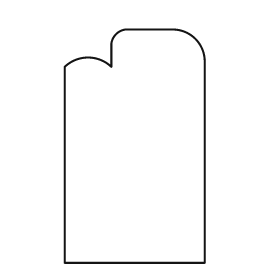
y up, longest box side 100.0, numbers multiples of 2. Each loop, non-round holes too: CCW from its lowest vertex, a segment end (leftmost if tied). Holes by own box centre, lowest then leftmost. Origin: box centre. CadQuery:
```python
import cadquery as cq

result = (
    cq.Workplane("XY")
    .moveTo(-30.0, -50.0)
    .lineTo(30.0, -50.0)
    .lineTo(30.0, 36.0)
    .threePointArc((26.0, 46.0), (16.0, 50.0))
    .lineTo(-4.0, 50.0)
    .threePointArc((-8.0, 48.0), (-10.0, 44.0))
    .lineTo(-10.0, 34.0)
    .threePointArc((-20.0, 38.0), (-30.0, 34.0))
    .close()
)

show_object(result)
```